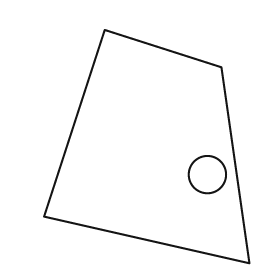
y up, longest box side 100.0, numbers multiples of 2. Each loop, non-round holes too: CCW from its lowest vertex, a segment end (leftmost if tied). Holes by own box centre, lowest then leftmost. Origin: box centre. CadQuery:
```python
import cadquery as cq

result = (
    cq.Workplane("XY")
    .moveTo(44.0, -50.0)
    .lineTo(32.0, 34.0)
    .lineTo(-18.0, 50.0)
    .lineTo(-44.0, -30.0)
    .close()
    .moveTo(26.0, -12.0)
    .circle(8.0)
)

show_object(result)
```